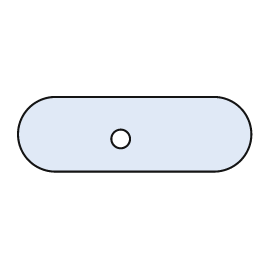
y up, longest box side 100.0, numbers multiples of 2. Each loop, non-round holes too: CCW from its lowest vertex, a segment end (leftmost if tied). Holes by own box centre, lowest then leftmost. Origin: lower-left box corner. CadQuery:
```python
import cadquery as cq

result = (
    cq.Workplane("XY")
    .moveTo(16.0, 0.0)
    .lineTo(84.0, 0.0)
    .threePointArc((100.0, 16.0), (84.0, 32.0))
    .lineTo(16.0, 32.0)
    .threePointArc((0.0, 16.0), (16.0, 0.0))
    .close()
    .moveTo(44.0, 14.0)
    .circle(4.0)
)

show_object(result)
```